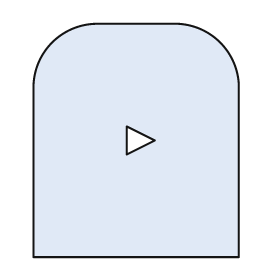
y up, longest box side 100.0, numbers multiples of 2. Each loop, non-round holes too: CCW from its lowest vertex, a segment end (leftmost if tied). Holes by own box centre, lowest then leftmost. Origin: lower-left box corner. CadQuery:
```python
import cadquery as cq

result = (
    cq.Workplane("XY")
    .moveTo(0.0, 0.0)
    .lineTo(88.0, 0.0)
    .lineTo(88.0, 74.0)
    .threePointArc((80.0, 92.0), (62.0, 100.0))
    .lineTo(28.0, 100.0)
    .threePointArc((8.0, 92.0), (0.0, 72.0))
    .close()
    .moveTo(40.0, 44.0)
    .lineTo(52.0, 50.0)
    .lineTo(40.0, 56.0)
    .close()
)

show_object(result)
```